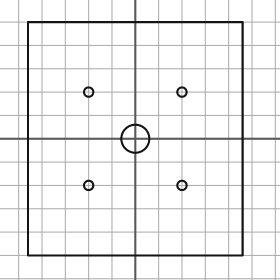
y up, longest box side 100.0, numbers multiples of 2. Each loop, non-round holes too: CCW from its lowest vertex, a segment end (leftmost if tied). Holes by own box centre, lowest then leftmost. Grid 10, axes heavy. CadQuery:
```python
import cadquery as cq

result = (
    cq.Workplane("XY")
    .moveTo(-46.0, -50.0)
    .lineTo(46.0, -50.0)
    .lineTo(46.0, 50.0)
    .lineTo(-46.0, 50.0)
    .close()
    .moveTo(-20.0, -20.0)
    .circle(2.0)
    .moveTo(20.0, -20.0)
    .circle(2.0)
    .moveTo(0.0, 0.0)
    .circle(6.0)
    .moveTo(-20.0, 20.0)
    .circle(2.0)
    .moveTo(20.0, 20.0)
    .circle(2.0)
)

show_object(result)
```